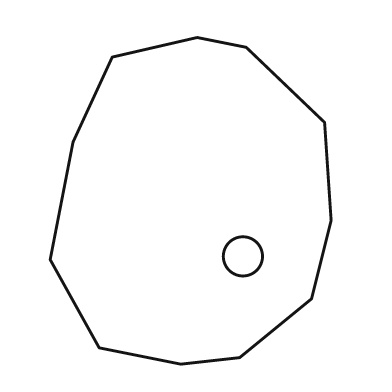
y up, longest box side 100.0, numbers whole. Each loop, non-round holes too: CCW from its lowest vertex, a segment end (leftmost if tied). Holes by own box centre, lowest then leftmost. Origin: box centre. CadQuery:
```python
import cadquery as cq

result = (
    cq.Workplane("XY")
    .moveTo(-3.0, -50.0)
    .lineTo(15.0, -48.0)
    .lineTo(37.0, -30.0)
    .lineTo(43.0, -6.0)
    .lineTo(41.0, 24.0)
    .lineTo(17.0, 47.0)
    .lineTo(2.0, 50.0)
    .lineTo(-24.0, 44.0)
    .lineTo(-36.0, 18.0)
    .lineTo(-43.0, -18.0)
    .lineTo(-28.0, -45.0)
    .close()
    .moveTo(16.0, -17.0)
    .circle(6.0)
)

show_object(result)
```